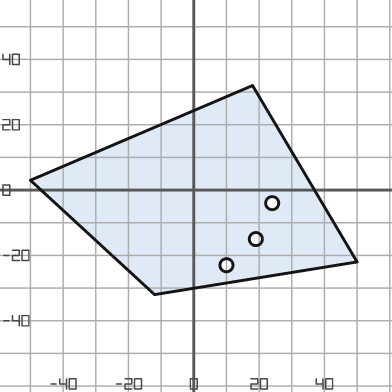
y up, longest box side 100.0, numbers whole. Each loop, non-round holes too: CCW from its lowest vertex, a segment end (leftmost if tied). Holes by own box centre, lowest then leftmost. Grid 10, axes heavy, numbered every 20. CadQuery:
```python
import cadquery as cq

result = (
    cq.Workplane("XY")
    .moveTo(-12.0, -32.0)
    .lineTo(50.0, -22.0)
    .lineTo(18.0, 32.0)
    .lineTo(-50.0, 3.0)
    .close()
    .moveTo(10.0, -23.0)
    .circle(2.0)
    .moveTo(19.0, -15.0)
    .circle(2.0)
    .moveTo(24.0, -4.0)
    .circle(2.0)
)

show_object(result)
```